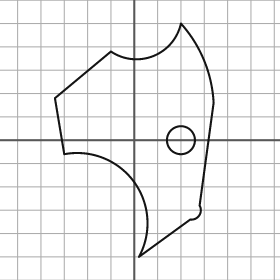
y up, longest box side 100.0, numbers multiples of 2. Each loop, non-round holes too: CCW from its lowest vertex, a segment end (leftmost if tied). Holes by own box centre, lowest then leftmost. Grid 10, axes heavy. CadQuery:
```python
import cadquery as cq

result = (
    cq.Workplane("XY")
    .moveTo(2.0, -50.0)
    .lineTo(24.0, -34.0)
    .threePointArc((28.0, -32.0), (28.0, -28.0))
    .lineTo(34.0, 16.0)
    .threePointArc((30.0, 34.0), (20.0, 50.0))
    .threePointArc((8.0, 36.0), (-10.0, 38.0))
    .lineTo(-34.0, 18.0)
    .lineTo(-30.0, -6.0)
    .threePointArc((0.0, -18.0), (2.0, -50.0))
    .close()
    .moveTo(20.0, 0.0)
    .circle(6.0)
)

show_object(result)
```